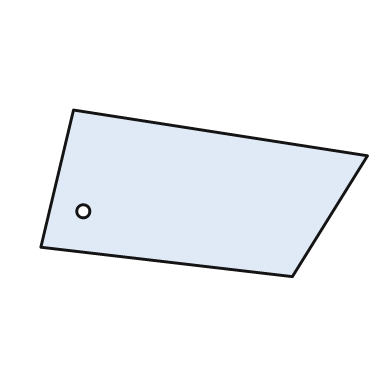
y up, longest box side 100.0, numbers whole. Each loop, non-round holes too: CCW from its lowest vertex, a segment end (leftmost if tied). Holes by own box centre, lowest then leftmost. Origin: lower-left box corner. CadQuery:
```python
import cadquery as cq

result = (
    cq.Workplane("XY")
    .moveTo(77.0, 0.0)
    .lineTo(100.0, 37.0)
    .lineTo(10.0, 51.0)
    .lineTo(0.0, 9.0)
    .close()
    .moveTo(13.0, 20.0)
    .circle(2.0)
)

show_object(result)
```